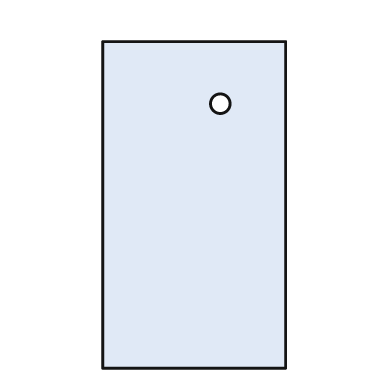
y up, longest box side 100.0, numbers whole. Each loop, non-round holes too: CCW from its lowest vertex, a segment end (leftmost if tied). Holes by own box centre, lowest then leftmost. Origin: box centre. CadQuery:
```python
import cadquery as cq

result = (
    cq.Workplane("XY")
    .moveTo(-28.0, -50.0)
    .lineTo(28.0, -50.0)
    .lineTo(28.0, 50.0)
    .lineTo(-28.0, 50.0)
    .close()
    .moveTo(8.0, 31.0)
    .circle(3.0)
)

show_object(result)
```